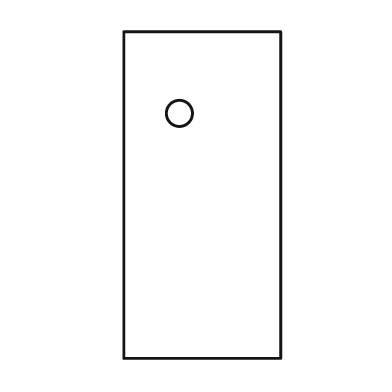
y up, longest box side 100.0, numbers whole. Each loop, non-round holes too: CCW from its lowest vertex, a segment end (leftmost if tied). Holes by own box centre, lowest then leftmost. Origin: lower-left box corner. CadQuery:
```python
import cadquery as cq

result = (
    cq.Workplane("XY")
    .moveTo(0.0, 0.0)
    .lineTo(48.0, 0.0)
    .lineTo(48.0, 100.0)
    .lineTo(0.0, 100.0)
    .close()
    .moveTo(17.0, 75.0)
    .circle(4.0)
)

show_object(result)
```